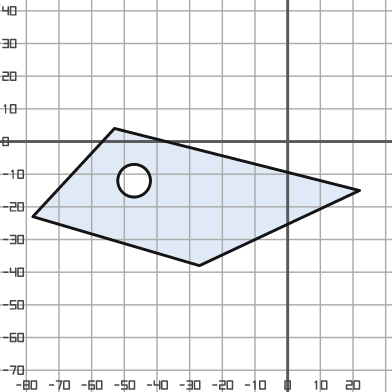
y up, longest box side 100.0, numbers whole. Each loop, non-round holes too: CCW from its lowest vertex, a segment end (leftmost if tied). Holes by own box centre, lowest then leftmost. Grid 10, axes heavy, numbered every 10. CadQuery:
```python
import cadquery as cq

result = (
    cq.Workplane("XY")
    .moveTo(-27.0, -38.0)
    .lineTo(22.0, -15.0)
    .lineTo(-53.0, 4.0)
    .lineTo(-78.0, -23.0)
    .close()
    .moveTo(-47.0, -12.0)
    .circle(5.0)
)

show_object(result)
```